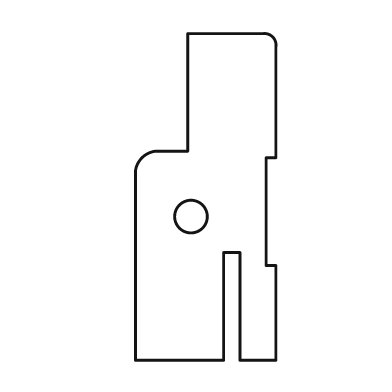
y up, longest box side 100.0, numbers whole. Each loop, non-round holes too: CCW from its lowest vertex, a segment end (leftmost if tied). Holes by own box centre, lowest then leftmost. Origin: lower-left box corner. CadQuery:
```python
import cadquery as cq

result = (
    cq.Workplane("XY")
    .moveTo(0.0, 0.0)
    .lineTo(27.0, 0.0)
    .lineTo(27.0, 33.0)
    .lineTo(32.0, 33.0)
    .lineTo(32.0, 0.0)
    .lineTo(43.0, 0.0)
    .lineTo(43.0, 29.0)
    .lineTo(40.0, 29.0)
    .lineTo(40.0, 62.0)
    .lineTo(43.0, 62.0)
    .lineTo(43.0, 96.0)
    .threePointArc((42.0, 99.0), (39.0, 100.0))
    .lineTo(16.0, 100.0)
    .lineTo(16.0, 64.0)
    .lineTo(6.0, 64.0)
    .threePointArc((2.0, 62.0), (0.0, 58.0))
    .close()
    .moveTo(17.0, 44.0)
    .circle(5.0)
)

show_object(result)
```